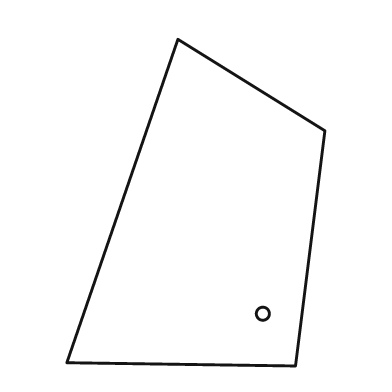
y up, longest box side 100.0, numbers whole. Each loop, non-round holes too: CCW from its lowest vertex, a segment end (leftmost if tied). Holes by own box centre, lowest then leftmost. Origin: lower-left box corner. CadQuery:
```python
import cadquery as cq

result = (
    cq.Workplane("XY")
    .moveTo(70.0, 0.0)
    .lineTo(79.0, 72.0)
    .lineTo(34.0, 100.0)
    .lineTo(0.0, 1.0)
    .close()
    .moveTo(60.0, 16.0)
    .circle(2.0)
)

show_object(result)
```